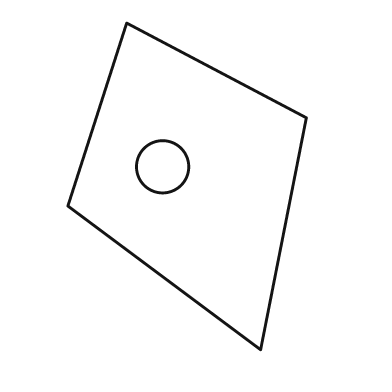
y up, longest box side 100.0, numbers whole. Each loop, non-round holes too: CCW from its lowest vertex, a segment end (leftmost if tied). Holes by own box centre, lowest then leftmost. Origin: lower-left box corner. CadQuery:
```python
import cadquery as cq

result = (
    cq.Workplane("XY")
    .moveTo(59.0, 0.0)
    .lineTo(73.0, 71.0)
    .lineTo(18.0, 100.0)
    .lineTo(0.0, 44.0)
    .close()
    .moveTo(29.0, 56.0)
    .circle(8.0)
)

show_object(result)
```